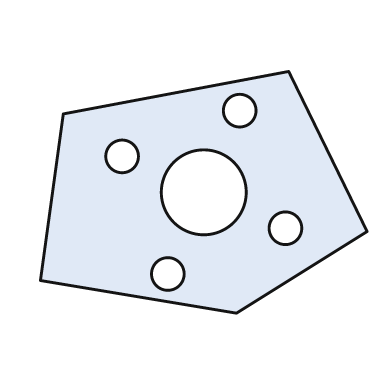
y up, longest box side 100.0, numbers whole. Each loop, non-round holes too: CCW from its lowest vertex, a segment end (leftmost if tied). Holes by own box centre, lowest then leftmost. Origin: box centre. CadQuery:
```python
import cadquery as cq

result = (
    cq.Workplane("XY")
    .moveTo(10.0, -37.0)
    .lineTo(50.0, -12.0)
    .lineTo(26.0, 37.0)
    .lineTo(-43.0, 24.0)
    .lineTo(-50.0, -27.0)
    .close()
    .moveTo(-11.0, -25.0)
    .circle(5.0)
    .moveTo(25.0, -11.0)
    .circle(5.0)
    .moveTo(0.0, 0.0)
    .circle(13.0)
    .moveTo(-25.0, 11.0)
    .circle(5.0)
    .moveTo(11.0, 25.0)
    .circle(5.0)
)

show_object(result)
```